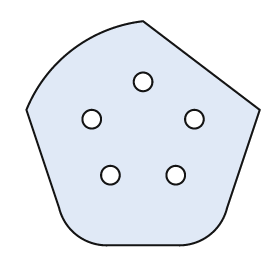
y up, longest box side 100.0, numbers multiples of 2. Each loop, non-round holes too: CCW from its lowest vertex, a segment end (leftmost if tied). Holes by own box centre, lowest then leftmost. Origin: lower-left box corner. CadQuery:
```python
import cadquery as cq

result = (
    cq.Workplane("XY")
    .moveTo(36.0, 0.0)
    .lineTo(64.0, 0.0)
    .threePointArc((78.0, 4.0), (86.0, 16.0))
    .lineTo(100.0, 58.0)
    .lineTo(50.0, 96.0)
    .threePointArc((20.0, 84.0), (0.0, 58.0))
    .lineTo(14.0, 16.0)
    .threePointArc((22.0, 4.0), (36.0, 0.0))
    .close()
    .moveTo(36.0, 30.0)
    .circle(4.0)
    .moveTo(64.0, 30.0)
    .circle(4.0)
    .moveTo(28.0, 54.0)
    .circle(4.0)
    .moveTo(72.0, 54.0)
    .circle(4.0)
    .moveTo(50.0, 70.0)
    .circle(4.0)
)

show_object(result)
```